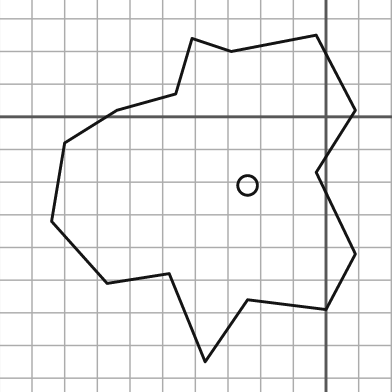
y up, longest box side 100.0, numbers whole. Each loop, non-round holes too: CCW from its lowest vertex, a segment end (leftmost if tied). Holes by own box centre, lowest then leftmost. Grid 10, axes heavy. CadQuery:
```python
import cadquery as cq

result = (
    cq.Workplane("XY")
    .moveTo(-37.0, -75.0)
    .lineTo(-24.0, -56.0)
    .lineTo(0.0, -59.0)
    .lineTo(9.0, -42.0)
    .lineTo(-3.0, -17.0)
    .lineTo(9.0, 2.0)
    .lineTo(-3.0, 25.0)
    .lineTo(-29.0, 20.0)
    .lineTo(-41.0, 24.0)
    .lineTo(-46.0, 7.0)
    .lineTo(-64.0, 2.0)
    .lineTo(-80.0, -8.0)
    .lineTo(-84.0, -32.0)
    .lineTo(-67.0, -51.0)
    .lineTo(-48.0, -48.0)
    .close()
    .moveTo(-24.0, -21.0)
    .circle(3.0)
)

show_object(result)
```